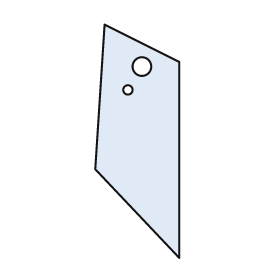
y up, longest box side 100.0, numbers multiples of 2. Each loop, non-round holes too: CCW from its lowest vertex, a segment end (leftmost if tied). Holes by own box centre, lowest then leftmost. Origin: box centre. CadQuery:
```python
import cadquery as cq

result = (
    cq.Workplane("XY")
    .moveTo(18.0, -50.0)
    .lineTo(18.0, 34.0)
    .lineTo(-14.0, 50.0)
    .lineTo(-18.0, -12.0)
    .close()
    .moveTo(-4.0, 22.0)
    .circle(2.0)
    .moveTo(2.0, 32.0)
    .circle(4.0)
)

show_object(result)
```